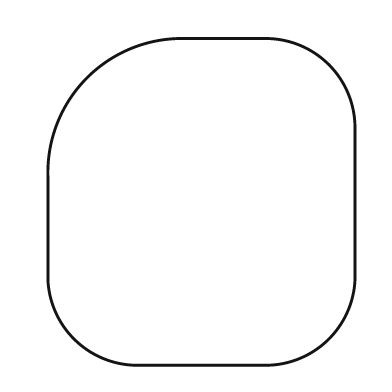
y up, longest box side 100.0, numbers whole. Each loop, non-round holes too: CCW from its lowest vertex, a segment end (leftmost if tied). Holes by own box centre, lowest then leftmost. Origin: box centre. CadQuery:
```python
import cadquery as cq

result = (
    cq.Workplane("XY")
    .moveTo(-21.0, -50.0)
    .lineTo(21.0, -50.0)
    .threePointArc((39.0, -42.0), (47.0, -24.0))
    .lineTo(47.0, 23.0)
    .threePointArc((39.0, 42.0), (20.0, 50.0))
    .lineTo(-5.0, 50.0)
    .threePointArc((-35.0, 38.0), (-47.0, 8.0))
    .lineTo(-47.0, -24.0)
    .threePointArc((-39.0, -42.0), (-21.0, -50.0))
    .close()
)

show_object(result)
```